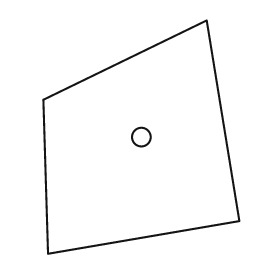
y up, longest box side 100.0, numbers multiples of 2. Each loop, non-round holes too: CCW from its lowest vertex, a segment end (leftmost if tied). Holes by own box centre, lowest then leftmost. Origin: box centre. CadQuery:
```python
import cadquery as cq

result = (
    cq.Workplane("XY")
    .moveTo(-40.0, -50.0)
    .lineTo(42.0, -36.0)
    .lineTo(28.0, 50.0)
    .lineTo(-42.0, 16.0)
    .close()
    .moveTo(0.0, 0.0)
    .circle(4.0)
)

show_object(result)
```